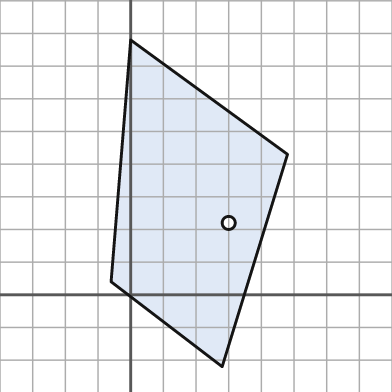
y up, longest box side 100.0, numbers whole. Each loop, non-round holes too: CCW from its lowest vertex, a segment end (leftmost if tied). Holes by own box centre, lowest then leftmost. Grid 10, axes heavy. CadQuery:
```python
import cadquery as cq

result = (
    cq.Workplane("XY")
    .moveTo(28.0, -22.0)
    .lineTo(48.0, 43.0)
    .lineTo(0.0, 78.0)
    .lineTo(-6.0, 4.0)
    .close()
    .moveTo(30.0, 22.0)
    .circle(2.0)
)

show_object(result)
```